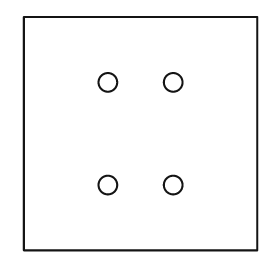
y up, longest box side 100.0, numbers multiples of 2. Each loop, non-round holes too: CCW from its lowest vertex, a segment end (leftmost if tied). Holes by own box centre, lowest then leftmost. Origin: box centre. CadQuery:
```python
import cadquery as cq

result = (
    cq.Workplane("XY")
    .moveTo(-50.0, -50.0)
    .lineTo(50.0, -50.0)
    .lineTo(50.0, 50.0)
    .lineTo(-50.0, 50.0)
    .close()
    .moveTo(-14.0, -22.0)
    .circle(4.0)
    .moveTo(14.0, -22.0)
    .circle(4.0)
    .moveTo(-14.0, 22.0)
    .circle(4.0)
    .moveTo(14.0, 22.0)
    .circle(4.0)
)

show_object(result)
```